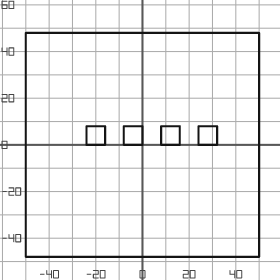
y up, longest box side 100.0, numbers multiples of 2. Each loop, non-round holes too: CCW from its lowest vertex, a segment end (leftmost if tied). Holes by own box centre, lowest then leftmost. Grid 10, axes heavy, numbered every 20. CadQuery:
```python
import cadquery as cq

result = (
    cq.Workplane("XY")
    .moveTo(-50.0, -48.0)
    .lineTo(50.0, -48.0)
    .lineTo(50.0, 48.0)
    .lineTo(-50.0, 48.0)
    .close()
    .moveTo(-24.0, 0.0)
    .lineTo(-16.0, 0.0)
    .lineTo(-16.0, 8.0)
    .lineTo(-24.0, 8.0)
    .close()
    .moveTo(-8.0, 0.0)
    .lineTo(0.0, 0.0)
    .lineTo(0.0, 8.0)
    .lineTo(-8.0, 8.0)
    .close()
    .moveTo(8.0, 0.0)
    .lineTo(16.0, 0.0)
    .lineTo(16.0, 8.0)
    .lineTo(8.0, 8.0)
    .close()
    .moveTo(24.0, 0.0)
    .lineTo(32.0, 0.0)
    .lineTo(32.0, 8.0)
    .lineTo(24.0, 8.0)
    .close()
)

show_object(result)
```